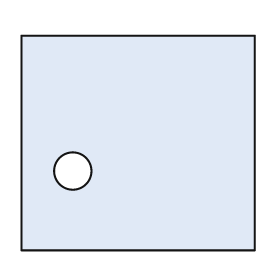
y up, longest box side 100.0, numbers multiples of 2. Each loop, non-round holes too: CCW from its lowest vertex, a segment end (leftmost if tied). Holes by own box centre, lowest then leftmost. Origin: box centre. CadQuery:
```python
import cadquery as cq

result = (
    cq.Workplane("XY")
    .moveTo(-50.0, -46.0)
    .lineTo(50.0, -46.0)
    .lineTo(50.0, 46.0)
    .lineTo(-50.0, 46.0)
    .close()
    .moveTo(-28.0, -12.0)
    .circle(8.0)
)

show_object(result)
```